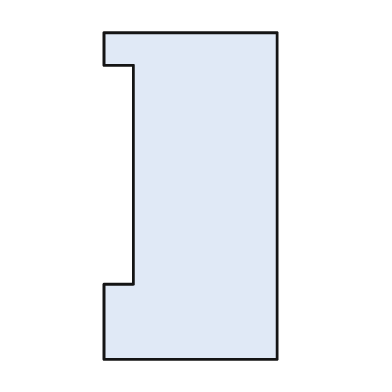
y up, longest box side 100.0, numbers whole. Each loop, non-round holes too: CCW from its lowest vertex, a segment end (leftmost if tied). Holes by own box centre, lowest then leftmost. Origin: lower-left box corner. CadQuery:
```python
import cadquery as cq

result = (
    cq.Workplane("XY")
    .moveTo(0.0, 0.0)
    .lineTo(53.0, 0.0)
    .lineTo(53.0, 100.0)
    .lineTo(0.0, 100.0)
    .lineTo(0.0, 90.0)
    .lineTo(9.0, 90.0)
    .lineTo(9.0, 23.0)
    .lineTo(0.0, 23.0)
    .close()
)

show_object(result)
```